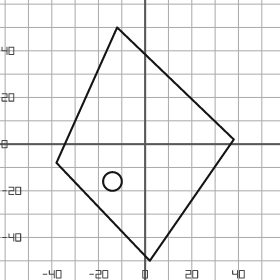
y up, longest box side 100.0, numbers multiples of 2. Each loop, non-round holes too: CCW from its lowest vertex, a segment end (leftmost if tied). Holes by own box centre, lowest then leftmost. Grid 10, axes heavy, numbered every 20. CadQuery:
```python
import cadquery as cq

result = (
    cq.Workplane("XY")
    .moveTo(2.0, -50.0)
    .lineTo(38.0, 2.0)
    .lineTo(-12.0, 50.0)
    .lineTo(-38.0, -8.0)
    .close()
    .moveTo(-14.0, -16.0)
    .circle(4.0)
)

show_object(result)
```